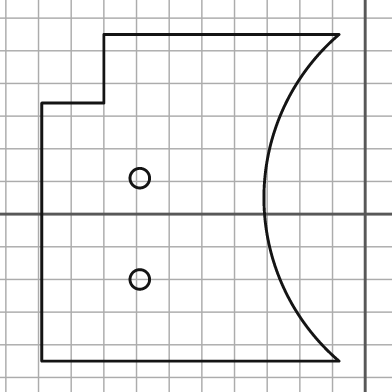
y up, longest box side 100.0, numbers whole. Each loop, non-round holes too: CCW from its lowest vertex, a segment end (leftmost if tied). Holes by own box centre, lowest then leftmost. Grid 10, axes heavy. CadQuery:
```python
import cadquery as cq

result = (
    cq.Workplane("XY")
    .moveTo(-99.0, -45.0)
    .lineTo(-8.0, -45.0)
    .threePointArc((-31.0, 5.0), (-8.0, 55.0))
    .lineTo(-80.0, 55.0)
    .lineTo(-80.0, 34.0)
    .lineTo(-99.0, 34.0)
    .close()
    .moveTo(-69.0, -20.0)
    .circle(3.0)
    .moveTo(-69.0, 11.0)
    .circle(3.0)
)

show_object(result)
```